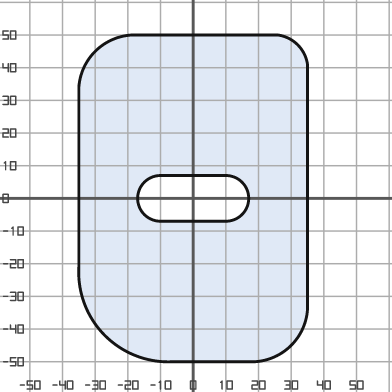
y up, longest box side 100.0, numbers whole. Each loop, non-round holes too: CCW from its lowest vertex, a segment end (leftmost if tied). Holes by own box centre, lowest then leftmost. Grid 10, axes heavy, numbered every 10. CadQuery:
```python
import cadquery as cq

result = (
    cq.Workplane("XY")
    .moveTo(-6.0, -50.0)
    .lineTo(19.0, -50.0)
    .threePointArc((30.0, -45.0), (35.0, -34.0))
    .lineTo(35.0, 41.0)
    .threePointArc((32.0, 47.0), (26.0, 50.0))
    .lineTo(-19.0, 50.0)
    .threePointArc((-30.0, 45.0), (-35.0, 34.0))
    .lineTo(-35.0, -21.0)
    .threePointArc((-27.0, -42.0), (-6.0, -50.0))
    .close()
    .moveTo(-10.0, -7.0)
    .lineTo(10.0, -7.0)
    .threePointArc((17.0, 0.0), (10.0, 7.0))
    .lineTo(-10.0, 7.0)
    .threePointArc((-17.0, 0.0), (-10.0, -7.0))
    .close()
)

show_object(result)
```